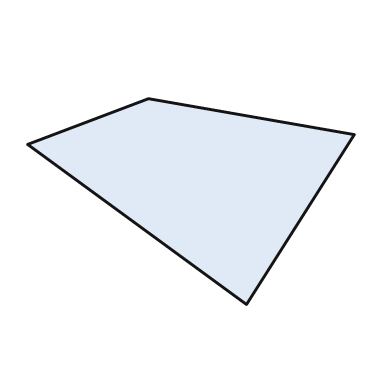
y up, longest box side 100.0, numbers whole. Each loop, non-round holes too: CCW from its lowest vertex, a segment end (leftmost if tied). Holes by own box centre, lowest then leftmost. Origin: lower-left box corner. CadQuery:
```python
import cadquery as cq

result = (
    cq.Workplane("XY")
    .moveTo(67.0, 0.0)
    .lineTo(100.0, 52.0)
    .lineTo(37.0, 63.0)
    .lineTo(0.0, 49.0)
    .close()
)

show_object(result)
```